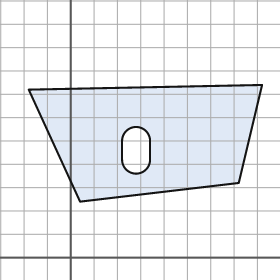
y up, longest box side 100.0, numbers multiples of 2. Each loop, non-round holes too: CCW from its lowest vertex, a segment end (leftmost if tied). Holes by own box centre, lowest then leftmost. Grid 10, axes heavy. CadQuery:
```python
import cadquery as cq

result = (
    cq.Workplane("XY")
    .moveTo(4.0, 24.0)
    .lineTo(72.0, 32.0)
    .lineTo(82.0, 74.0)
    .lineTo(-18.0, 72.0)
    .close()
    .moveTo(22.0, 42.0)
    .threePointArc((28.0, 36.0), (34.0, 42.0))
    .lineTo(34.0, 50.0)
    .threePointArc((28.0, 56.0), (22.0, 50.0))
    .close()
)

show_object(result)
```